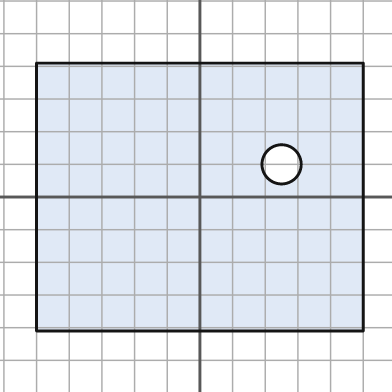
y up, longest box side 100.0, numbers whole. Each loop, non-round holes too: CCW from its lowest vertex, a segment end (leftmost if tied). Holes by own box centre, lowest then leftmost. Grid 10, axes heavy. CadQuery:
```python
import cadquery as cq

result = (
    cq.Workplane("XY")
    .moveTo(-50.0, -41.0)
    .lineTo(50.0, -41.0)
    .lineTo(50.0, 41.0)
    .lineTo(-50.0, 41.0)
    .close()
    .moveTo(25.0, 10.0)
    .circle(6.0)
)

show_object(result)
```